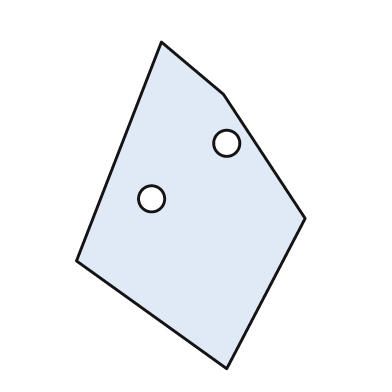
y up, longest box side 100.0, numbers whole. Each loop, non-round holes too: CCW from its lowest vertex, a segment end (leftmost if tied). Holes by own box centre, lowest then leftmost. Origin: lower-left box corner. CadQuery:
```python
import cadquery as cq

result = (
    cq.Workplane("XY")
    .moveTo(46.0, 0.0)
    .lineTo(70.0, 46.0)
    .lineTo(45.0, 84.0)
    .lineTo(26.0, 100.0)
    .lineTo(0.0, 33.0)
    .close()
    .moveTo(23.0, 52.0)
    .circle(4.0)
    .moveTo(46.0, 69.0)
    .circle(4.0)
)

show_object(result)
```